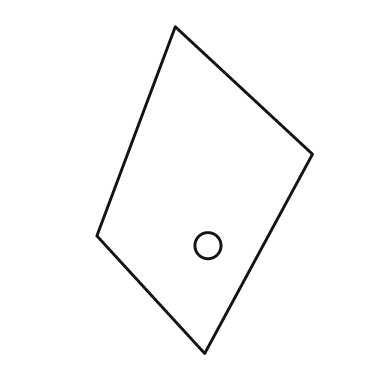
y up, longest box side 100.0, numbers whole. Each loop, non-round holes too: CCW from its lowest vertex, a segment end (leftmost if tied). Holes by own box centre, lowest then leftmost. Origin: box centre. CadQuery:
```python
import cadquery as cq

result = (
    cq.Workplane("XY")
    .moveTo(0.0, -50.0)
    .lineTo(33.0, 11.0)
    .lineTo(-9.0, 50.0)
    .lineTo(-33.0, -14.0)
    .close()
    .moveTo(1.0, -17.0)
    .circle(4.0)
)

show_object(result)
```